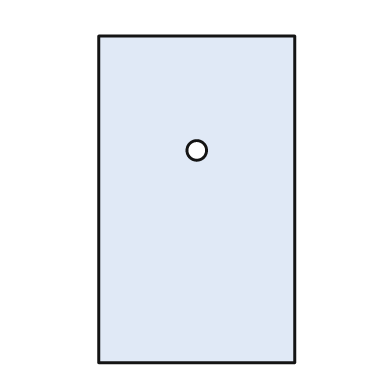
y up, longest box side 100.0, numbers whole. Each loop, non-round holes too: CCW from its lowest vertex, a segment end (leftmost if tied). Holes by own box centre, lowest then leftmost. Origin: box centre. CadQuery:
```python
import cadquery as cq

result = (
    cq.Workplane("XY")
    .moveTo(-30.0, -50.0)
    .lineTo(30.0, -50.0)
    .lineTo(30.0, 50.0)
    .lineTo(-30.0, 50.0)
    .close()
    .moveTo(0.0, 15.0)
    .circle(3.0)
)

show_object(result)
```